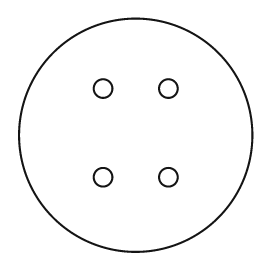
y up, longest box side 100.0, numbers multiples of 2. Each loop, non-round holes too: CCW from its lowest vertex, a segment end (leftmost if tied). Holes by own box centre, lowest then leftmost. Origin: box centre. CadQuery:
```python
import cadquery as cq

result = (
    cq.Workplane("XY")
    .moveTo(0.0, 0.0)
    .circle(50.0)
    .moveTo(-14.0, -18.0)
    .circle(4.0)
    .moveTo(14.0, -18.0)
    .circle(4.0)
    .moveTo(-14.0, 20.0)
    .circle(4.0)
    .moveTo(14.0, 20.0)
    .circle(4.0)
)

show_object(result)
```